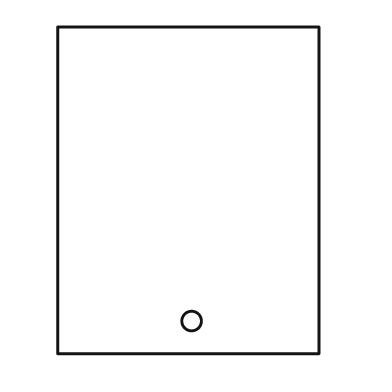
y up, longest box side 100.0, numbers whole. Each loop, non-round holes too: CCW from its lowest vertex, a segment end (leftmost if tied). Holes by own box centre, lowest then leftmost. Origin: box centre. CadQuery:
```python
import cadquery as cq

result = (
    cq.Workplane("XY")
    .moveTo(-40.0, -50.0)
    .lineTo(40.0, -50.0)
    .lineTo(40.0, 50.0)
    .lineTo(-40.0, 50.0)
    .close()
    .moveTo(1.0, -40.0)
    .circle(3.0)
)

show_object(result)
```